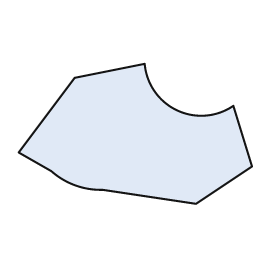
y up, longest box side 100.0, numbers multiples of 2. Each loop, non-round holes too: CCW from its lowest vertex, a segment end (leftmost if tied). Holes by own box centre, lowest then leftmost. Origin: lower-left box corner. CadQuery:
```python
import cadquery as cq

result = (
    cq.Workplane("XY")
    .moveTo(76.0, 0.0)
    .lineTo(100.0, 16.0)
    .lineTo(92.0, 42.0)
    .threePointArc((68.0, 40.0), (54.0, 60.0))
    .lineTo(24.0, 54.0)
    .lineTo(0.0, 22.0)
    .lineTo(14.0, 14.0)
    .threePointArc((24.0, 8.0), (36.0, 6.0))
    .close()
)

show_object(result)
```